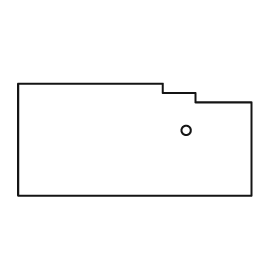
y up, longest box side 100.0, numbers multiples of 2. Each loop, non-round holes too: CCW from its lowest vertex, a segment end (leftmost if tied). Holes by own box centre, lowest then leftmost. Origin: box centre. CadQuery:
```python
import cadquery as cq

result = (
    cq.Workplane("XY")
    .moveTo(-50.0, -24.0)
    .lineTo(50.0, -24.0)
    .lineTo(50.0, 16.0)
    .lineTo(26.0, 16.0)
    .lineTo(26.0, 20.0)
    .lineTo(12.0, 20.0)
    .lineTo(12.0, 24.0)
    .lineTo(-50.0, 24.0)
    .close()
    .moveTo(22.0, 4.0)
    .circle(2.0)
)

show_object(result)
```